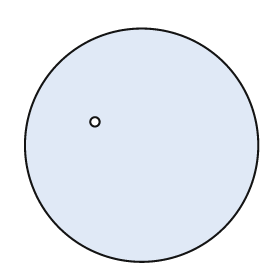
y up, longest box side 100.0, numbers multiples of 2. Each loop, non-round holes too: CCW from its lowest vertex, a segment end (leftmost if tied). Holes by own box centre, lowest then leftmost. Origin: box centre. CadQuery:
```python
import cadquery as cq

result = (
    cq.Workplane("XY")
    .moveTo(0.0, 0.0)
    .circle(50.0)
    .moveTo(-20.0, 10.0)
    .circle(2.0)
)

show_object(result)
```